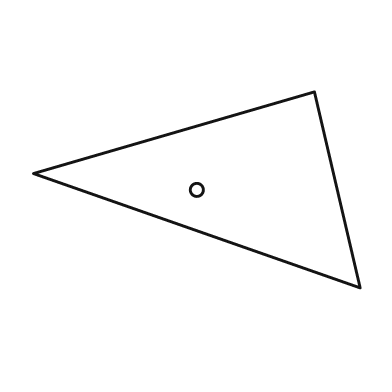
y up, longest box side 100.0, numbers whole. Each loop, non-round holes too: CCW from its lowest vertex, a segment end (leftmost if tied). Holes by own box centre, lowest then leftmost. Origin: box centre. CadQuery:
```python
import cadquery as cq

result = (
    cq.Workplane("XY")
    .moveTo(50.0, -30.0)
    .lineTo(36.0, 30.0)
    .lineTo(-50.0, 5.0)
    .close()
    .moveTo(0.0, 0.0)
    .circle(2.0)
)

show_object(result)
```